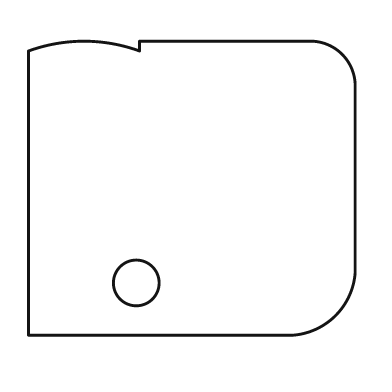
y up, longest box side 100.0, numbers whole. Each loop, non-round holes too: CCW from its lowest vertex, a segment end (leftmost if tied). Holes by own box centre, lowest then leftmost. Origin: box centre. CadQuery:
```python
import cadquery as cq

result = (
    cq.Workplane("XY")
    .moveTo(-50.0, -45.0)
    .lineTo(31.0, -45.0)
    .threePointArc((44.0, -39.0), (50.0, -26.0))
    .lineTo(50.0, 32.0)
    .threePointArc((46.0, 41.0), (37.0, 45.0))
    .lineTo(-16.0, 45.0)
    .lineTo(-16.0, 42.0)
    .threePointArc((-33.0, 45.0), (-50.0, 42.0))
    .close()
    .moveTo(-17.0, -29.0)
    .circle(7.0)
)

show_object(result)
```